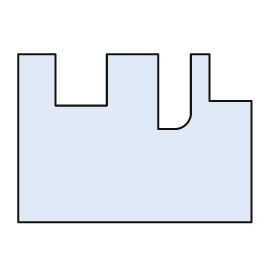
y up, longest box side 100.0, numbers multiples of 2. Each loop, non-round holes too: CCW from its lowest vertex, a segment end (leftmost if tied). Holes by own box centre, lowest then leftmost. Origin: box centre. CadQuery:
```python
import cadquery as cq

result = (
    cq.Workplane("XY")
    .moveTo(-50.0, -36.0)
    .lineTo(50.0, -36.0)
    .lineTo(50.0, 16.0)
    .lineTo(32.0, 16.0)
    .lineTo(32.0, 36.0)
    .lineTo(24.0, 36.0)
    .lineTo(24.0, 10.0)
    .threePointArc((22.0, 6.0), (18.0, 4.0))
    .lineTo(10.0, 4.0)
    .lineTo(10.0, 36.0)
    .lineTo(-12.0, 36.0)
    .lineTo(-12.0, 14.0)
    .lineTo(-34.0, 14.0)
    .lineTo(-34.0, 36.0)
    .lineTo(-50.0, 36.0)
    .close()
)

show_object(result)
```